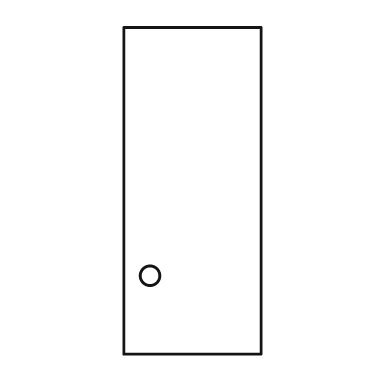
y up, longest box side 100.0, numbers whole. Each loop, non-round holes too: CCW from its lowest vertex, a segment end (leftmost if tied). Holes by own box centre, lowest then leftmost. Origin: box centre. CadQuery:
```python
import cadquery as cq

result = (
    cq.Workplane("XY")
    .moveTo(-21.0, -50.0)
    .lineTo(21.0, -50.0)
    .lineTo(21.0, 50.0)
    .lineTo(-21.0, 50.0)
    .close()
    .moveTo(-13.0, -26.0)
    .circle(3.0)
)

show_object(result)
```